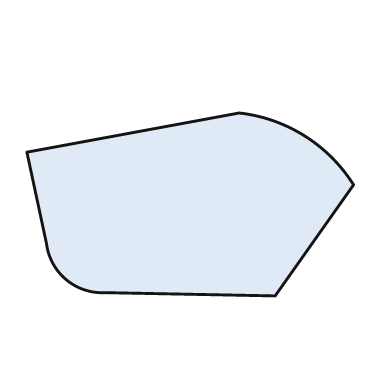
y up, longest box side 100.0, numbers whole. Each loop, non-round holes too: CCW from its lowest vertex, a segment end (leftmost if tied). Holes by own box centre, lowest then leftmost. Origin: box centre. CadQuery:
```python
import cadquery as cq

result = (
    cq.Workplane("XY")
    .moveTo(26.0, -28.0)
    .lineTo(50.0, 6.0)
    .threePointArc((35.0, 21.0), (15.0, 28.0))
    .lineTo(-50.0, 16.0)
    .lineTo(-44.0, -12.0)
    .threePointArc((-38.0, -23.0), (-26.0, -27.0))
    .close()
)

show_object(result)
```